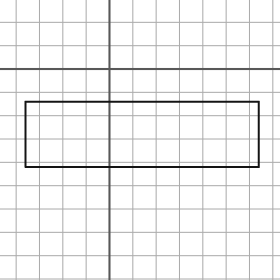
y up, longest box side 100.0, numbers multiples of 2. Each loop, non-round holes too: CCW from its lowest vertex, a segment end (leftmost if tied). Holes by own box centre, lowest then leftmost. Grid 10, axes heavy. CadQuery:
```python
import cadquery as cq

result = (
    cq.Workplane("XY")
    .moveTo(-36.0, -42.0)
    .lineTo(64.0, -42.0)
    .lineTo(64.0, -14.0)
    .lineTo(-36.0, -14.0)
    .close()
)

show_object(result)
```